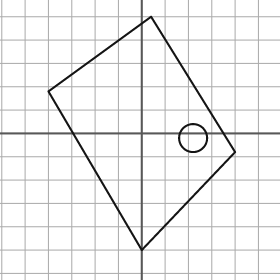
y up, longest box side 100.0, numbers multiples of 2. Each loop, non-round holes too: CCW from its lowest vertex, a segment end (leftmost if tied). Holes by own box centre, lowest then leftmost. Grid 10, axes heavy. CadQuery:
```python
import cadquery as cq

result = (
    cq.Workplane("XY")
    .moveTo(0.0, -50.0)
    .lineTo(40.0, -8.0)
    .lineTo(4.0, 50.0)
    .lineTo(-40.0, 18.0)
    .close()
    .moveTo(22.0, -2.0)
    .circle(6.0)
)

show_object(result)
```